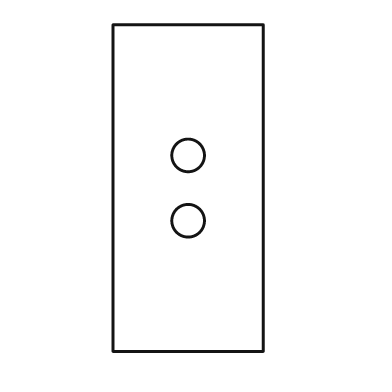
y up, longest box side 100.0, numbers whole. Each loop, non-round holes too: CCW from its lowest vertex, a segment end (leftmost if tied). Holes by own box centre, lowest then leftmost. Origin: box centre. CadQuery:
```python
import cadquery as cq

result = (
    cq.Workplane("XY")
    .moveTo(-23.0, -50.0)
    .lineTo(23.0, -50.0)
    .lineTo(23.0, 50.0)
    .lineTo(-23.0, 50.0)
    .close()
    .moveTo(0.0, -10.0)
    .circle(5.0)
    .moveTo(0.0, 10.0)
    .circle(5.0)
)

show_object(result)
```